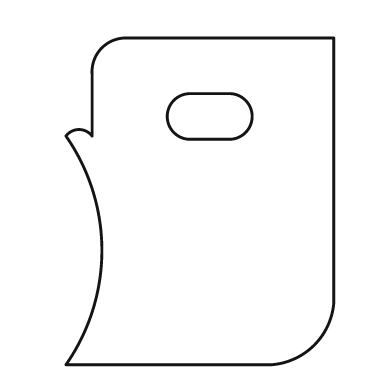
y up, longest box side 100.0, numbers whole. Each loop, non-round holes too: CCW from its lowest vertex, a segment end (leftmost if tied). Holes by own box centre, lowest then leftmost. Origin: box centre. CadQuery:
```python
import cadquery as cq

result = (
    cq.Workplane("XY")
    .moveTo(-41.0, -50.0)
    .lineTo(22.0, -50.0)
    .threePointArc((35.0, -44.0), (41.0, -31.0))
    .lineTo(41.0, 50.0)
    .lineTo(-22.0, 50.0)
    .threePointArc((-30.0, 47.0), (-33.0, 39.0))
    .lineTo(-33.0, 20.0)
    .threePointArc((-37.0, 22.0), (-41.0, 20.0))
    .threePointArc((-30.0, -15.0), (-41.0, -50.0))
    .close()
    .moveTo(-3.0, 19.0)
    .lineTo(9.0, 19.0)
    .threePointArc((16.0, 26.0), (9.0, 33.0))
    .lineTo(-3.0, 33.0)
    .threePointArc((-10.0, 26.0), (-3.0, 19.0))
    .close()
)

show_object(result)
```